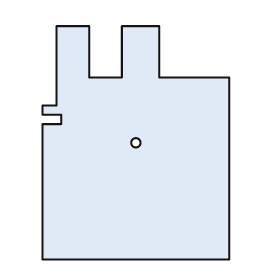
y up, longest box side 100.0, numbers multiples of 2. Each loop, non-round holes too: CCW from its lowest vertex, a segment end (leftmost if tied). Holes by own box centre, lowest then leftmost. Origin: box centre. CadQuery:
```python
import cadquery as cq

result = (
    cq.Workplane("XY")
    .moveTo(-40.0, -50.0)
    .lineTo(40.0, -50.0)
    .lineTo(40.0, 28.0)
    .lineTo(10.0, 28.0)
    .lineTo(10.0, 50.0)
    .lineTo(-6.0, 50.0)
    .lineTo(-6.0, 28.0)
    .lineTo(-20.0, 28.0)
    .lineTo(-20.0, 50.0)
    .lineTo(-34.0, 50.0)
    .lineTo(-34.0, 16.0)
    .lineTo(-40.0, 16.0)
    .lineTo(-40.0, 12.0)
    .lineTo(-32.0, 12.0)
    .lineTo(-32.0, 8.0)
    .lineTo(-40.0, 8.0)
    .close()
    .moveTo(0.0, 0.0)
    .circle(2.0)
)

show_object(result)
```